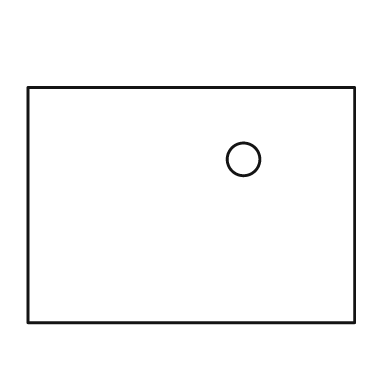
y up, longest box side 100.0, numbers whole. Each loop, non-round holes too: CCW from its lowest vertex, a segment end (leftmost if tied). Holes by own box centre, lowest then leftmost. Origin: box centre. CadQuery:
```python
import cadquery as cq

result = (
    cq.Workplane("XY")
    .moveTo(-50.0, -36.0)
    .lineTo(50.0, -36.0)
    .lineTo(50.0, 36.0)
    .lineTo(-50.0, 36.0)
    .close()
    .moveTo(16.0, 14.0)
    .circle(5.0)
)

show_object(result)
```